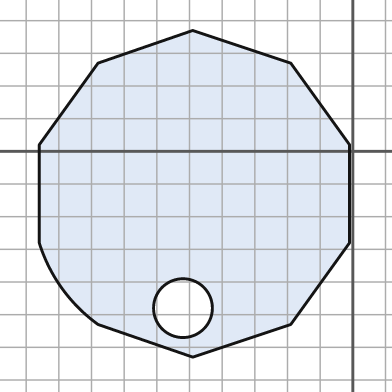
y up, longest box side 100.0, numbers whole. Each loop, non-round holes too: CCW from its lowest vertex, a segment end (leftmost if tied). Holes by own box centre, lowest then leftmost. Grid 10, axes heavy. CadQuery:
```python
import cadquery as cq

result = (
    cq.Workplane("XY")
    .moveTo(-49.0, -63.0)
    .lineTo(-19.0, -53.0)
    .lineTo(-1.0, -28.0)
    .lineTo(-1.0, 2.0)
    .lineTo(-19.0, 27.0)
    .lineTo(-49.0, 37.0)
    .lineTo(-78.0, 27.0)
    .lineTo(-96.0, 2.0)
    .lineTo(-96.0, -28.0)
    .threePointArc((-89.0, -42.0), (-78.0, -53.0))
    .close()
    .moveTo(-52.0, -48.0)
    .circle(9.0)
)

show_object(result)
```